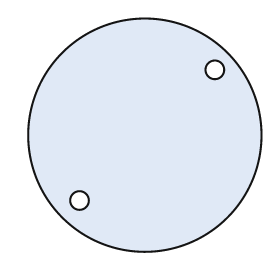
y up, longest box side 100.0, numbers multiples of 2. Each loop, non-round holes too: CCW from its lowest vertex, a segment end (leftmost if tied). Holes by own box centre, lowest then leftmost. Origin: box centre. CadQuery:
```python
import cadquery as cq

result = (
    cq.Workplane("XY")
    .moveTo(0.0, 0.0)
    .circle(50.0)
    .moveTo(-28.0, -28.0)
    .circle(4.0)
    .moveTo(30.0, 28.0)
    .circle(4.0)
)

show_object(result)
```